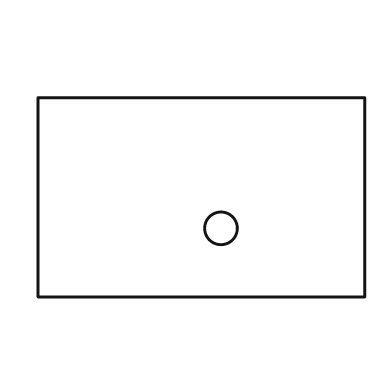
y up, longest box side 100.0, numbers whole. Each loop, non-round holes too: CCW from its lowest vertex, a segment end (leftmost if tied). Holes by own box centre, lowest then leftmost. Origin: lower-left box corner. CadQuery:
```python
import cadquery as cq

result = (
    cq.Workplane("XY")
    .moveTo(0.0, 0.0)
    .lineTo(100.0, 0.0)
    .lineTo(100.0, 61.0)
    .lineTo(0.0, 61.0)
    .close()
    .moveTo(56.0, 21.0)
    .circle(5.0)
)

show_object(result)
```